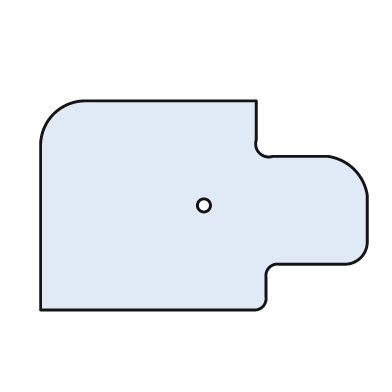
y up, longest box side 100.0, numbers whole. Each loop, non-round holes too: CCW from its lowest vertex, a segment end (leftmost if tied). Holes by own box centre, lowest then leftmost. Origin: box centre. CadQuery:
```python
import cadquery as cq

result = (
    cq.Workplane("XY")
    .moveTo(-50.0, -32.0)
    .lineTo(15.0, -32.0)
    .threePointArc((18.0, -31.0), (19.0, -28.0))
    .lineTo(19.0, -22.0)
    .threePointArc((20.0, -19.0), (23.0, -18.0))
    .lineTo(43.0, -18.0)
    .threePointArc((48.0, -16.0), (50.0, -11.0))
    .lineTo(50.0, 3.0)
    .threePointArc((46.0, 11.0), (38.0, 15.0))
    .lineTo(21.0, 15.0)
    .threePointArc((17.0, 16.0), (16.0, 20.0))
    .lineTo(16.0, 32.0)
    .lineTo(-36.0, 32.0)
    .threePointArc((-46.0, 28.0), (-50.0, 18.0))
    .close()
    .moveTo(0.0, 0.0)
    .circle(2.0)
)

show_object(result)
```